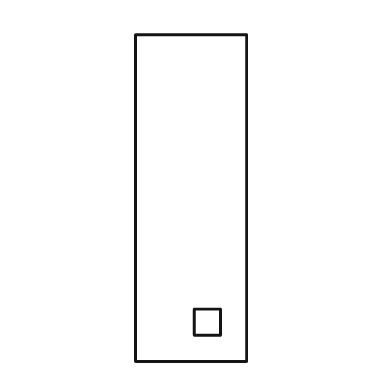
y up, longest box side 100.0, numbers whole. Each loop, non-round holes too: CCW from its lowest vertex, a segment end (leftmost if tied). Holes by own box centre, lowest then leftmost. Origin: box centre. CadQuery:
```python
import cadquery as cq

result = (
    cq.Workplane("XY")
    .moveTo(-17.0, -50.0)
    .lineTo(17.0, -50.0)
    .lineTo(17.0, 50.0)
    .lineTo(-17.0, 50.0)
    .close()
    .moveTo(1.0, -42.0)
    .lineTo(9.0, -42.0)
    .lineTo(9.0, -34.0)
    .lineTo(1.0, -34.0)
    .close()
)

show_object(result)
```